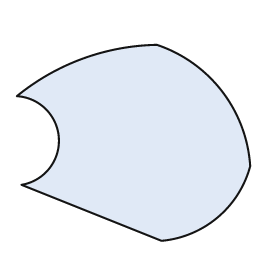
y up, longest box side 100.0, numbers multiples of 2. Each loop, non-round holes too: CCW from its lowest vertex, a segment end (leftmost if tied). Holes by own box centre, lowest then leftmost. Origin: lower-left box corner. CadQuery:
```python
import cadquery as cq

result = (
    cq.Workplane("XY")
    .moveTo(62.0, 0.0)
    .threePointArc((86.0, 10.0), (100.0, 32.0))
    .threePointArc((88.0, 64.0), (60.0, 84.0))
    .threePointArc((28.0, 78.0), (0.0, 62.0))
    .threePointArc((18.0, 44.0), (2.0, 24.0))
    .close()
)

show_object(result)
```